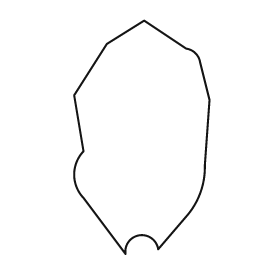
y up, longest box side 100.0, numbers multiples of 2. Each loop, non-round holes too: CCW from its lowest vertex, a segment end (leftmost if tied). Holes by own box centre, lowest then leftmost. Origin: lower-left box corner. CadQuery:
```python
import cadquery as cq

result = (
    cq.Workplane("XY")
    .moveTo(22.0, 0.0)
    .threePointArc((28.0, 8.0), (36.0, 2.0))
    .lineTo(48.0, 16.0)
    .threePointArc((54.0, 26.0), (56.0, 38.0))
    .lineTo(58.0, 66.0)
    .lineTo(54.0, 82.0)
    .threePointArc((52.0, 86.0), (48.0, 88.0))
    .lineTo(30.0, 100.0)
    .lineTo(14.0, 90.0)
    .lineTo(0.0, 68.0)
    .lineTo(4.0, 44.0)
    .threePointArc((0.0, 34.0), (4.0, 24.0))
    .close()
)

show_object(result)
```